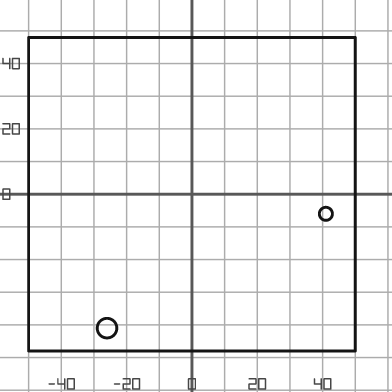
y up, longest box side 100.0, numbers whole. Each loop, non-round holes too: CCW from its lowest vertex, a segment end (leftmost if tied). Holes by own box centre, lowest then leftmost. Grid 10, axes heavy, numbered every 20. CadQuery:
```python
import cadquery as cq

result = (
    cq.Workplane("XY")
    .moveTo(-50.0, -48.0)
    .lineTo(50.0, -48.0)
    .lineTo(50.0, 48.0)
    .lineTo(-50.0, 48.0)
    .close()
    .moveTo(-26.0, -41.0)
    .circle(3.0)
    .moveTo(41.0, -6.0)
    .circle(2.0)
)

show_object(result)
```